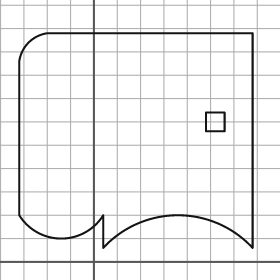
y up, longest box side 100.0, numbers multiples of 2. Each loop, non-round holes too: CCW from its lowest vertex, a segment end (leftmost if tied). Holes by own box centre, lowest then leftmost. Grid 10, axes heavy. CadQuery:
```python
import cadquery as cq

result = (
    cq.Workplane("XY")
    .moveTo(4.0, 6.0)
    .threePointArc((36.0, 20.0), (68.0, 6.0))
    .lineTo(68.0, 98.0)
    .lineTo(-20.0, 98.0)
    .threePointArc((-28.0, 94.0), (-32.0, 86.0))
    .lineTo(-32.0, 20.0)
    .threePointArc((-14.0, 10.0), (4.0, 20.0))
    .close()
    .moveTo(48.0, 56.0)
    .lineTo(56.0, 56.0)
    .lineTo(56.0, 64.0)
    .lineTo(48.0, 64.0)
    .close()
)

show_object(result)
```